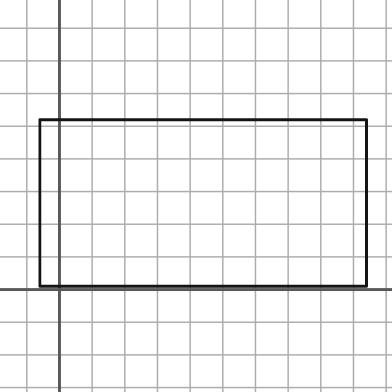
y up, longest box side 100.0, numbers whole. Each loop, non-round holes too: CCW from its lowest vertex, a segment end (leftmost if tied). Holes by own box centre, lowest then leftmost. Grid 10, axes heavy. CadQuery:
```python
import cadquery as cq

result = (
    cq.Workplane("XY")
    .moveTo(-6.0, 1.0)
    .lineTo(94.0, 1.0)
    .lineTo(94.0, 52.0)
    .lineTo(-6.0, 52.0)
    .close()
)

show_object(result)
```